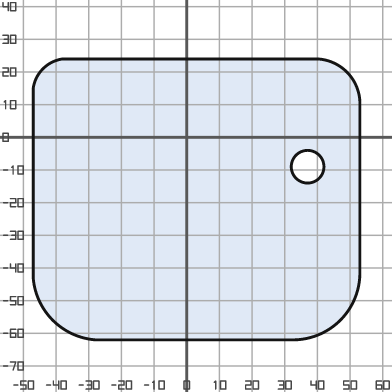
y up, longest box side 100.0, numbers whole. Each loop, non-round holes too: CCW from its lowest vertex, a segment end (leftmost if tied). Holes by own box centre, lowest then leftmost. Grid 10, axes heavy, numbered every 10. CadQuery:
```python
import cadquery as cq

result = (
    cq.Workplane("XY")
    .moveTo(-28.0, -62.0)
    .lineTo(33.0, -62.0)
    .threePointArc((47.0, -56.0), (53.0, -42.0))
    .lineTo(53.0, 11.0)
    .threePointArc((49.0, 20.0), (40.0, 24.0))
    .lineTo(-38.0, 24.0)
    .threePointArc((-44.0, 21.0), (-47.0, 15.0))
    .lineTo(-47.0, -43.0)
    .threePointArc((-41.0, -56.0), (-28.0, -62.0))
    .close()
    .moveTo(37.0, -9.0)
    .circle(5.0)
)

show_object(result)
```